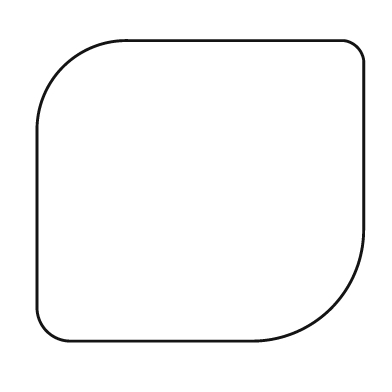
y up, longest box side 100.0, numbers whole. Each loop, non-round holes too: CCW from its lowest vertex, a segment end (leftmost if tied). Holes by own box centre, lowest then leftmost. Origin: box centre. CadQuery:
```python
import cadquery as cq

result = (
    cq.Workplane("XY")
    .moveTo(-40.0, -46.0)
    .lineTo(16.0, -46.0)
    .threePointArc((40.0, -36.0), (50.0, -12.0))
    .lineTo(50.0, 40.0)
    .threePointArc((48.0, 44.0), (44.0, 46.0))
    .lineTo(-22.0, 46.0)
    .threePointArc((-42.0, 38.0), (-50.0, 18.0))
    .lineTo(-50.0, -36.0)
    .threePointArc((-47.0, -43.0), (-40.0, -46.0))
    .close()
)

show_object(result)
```